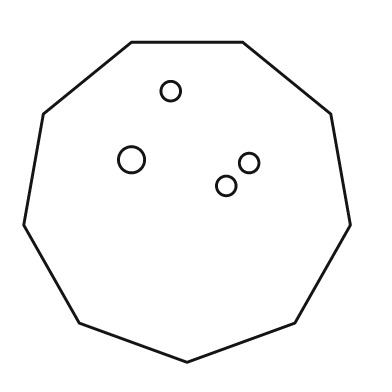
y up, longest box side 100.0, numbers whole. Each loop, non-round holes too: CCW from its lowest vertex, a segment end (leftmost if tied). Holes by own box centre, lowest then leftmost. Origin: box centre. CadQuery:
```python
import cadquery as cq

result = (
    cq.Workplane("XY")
    .moveTo(0.0, -49.0)
    .lineTo(33.0, -37.0)
    .lineTo(50.0, -7.0)
    .lineTo(44.0, 27.0)
    .lineTo(17.0, 49.0)
    .lineTo(-17.0, 49.0)
    .lineTo(-44.0, 27.0)
    .lineTo(-50.0, -7.0)
    .lineTo(-33.0, -37.0)
    .close()
    .moveTo(12.0, 5.0)
    .circle(3.0)
    .moveTo(19.0, 12.0)
    .circle(3.0)
    .moveTo(-17.0, 13.0)
    .circle(4.0)
    .moveTo(-5.0, 34.0)
    .circle(3.0)
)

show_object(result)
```